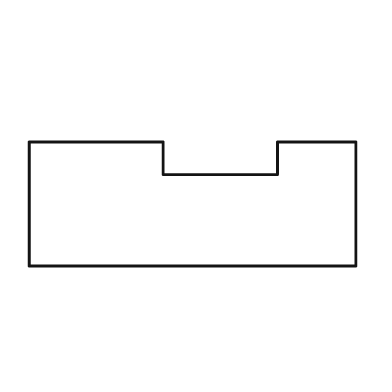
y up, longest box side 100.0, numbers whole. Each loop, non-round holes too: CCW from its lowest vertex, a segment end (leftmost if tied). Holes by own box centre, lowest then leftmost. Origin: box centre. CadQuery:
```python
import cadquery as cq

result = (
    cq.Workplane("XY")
    .moveTo(-50.0, -19.0)
    .lineTo(50.0, -19.0)
    .lineTo(50.0, 19.0)
    .lineTo(26.0, 19.0)
    .lineTo(26.0, 9.0)
    .lineTo(-9.0, 9.0)
    .lineTo(-9.0, 19.0)
    .lineTo(-50.0, 19.0)
    .close()
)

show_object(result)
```